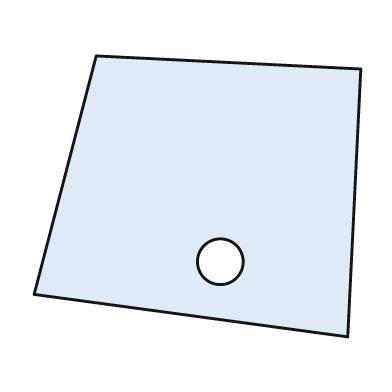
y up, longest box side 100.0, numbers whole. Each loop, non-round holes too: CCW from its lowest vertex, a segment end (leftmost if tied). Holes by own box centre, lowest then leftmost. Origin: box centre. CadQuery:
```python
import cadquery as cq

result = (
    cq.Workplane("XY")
    .moveTo(46.0, -43.0)
    .lineTo(50.0, 39.0)
    .lineTo(-31.0, 43.0)
    .lineTo(-50.0, -30.0)
    .close()
    .moveTo(7.0, -20.0)
    .circle(7.0)
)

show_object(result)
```